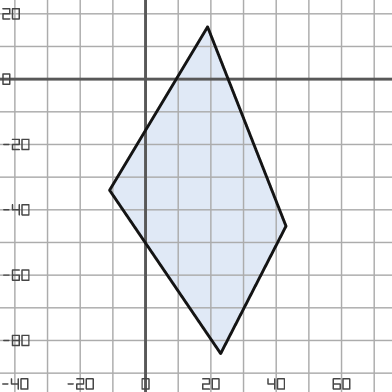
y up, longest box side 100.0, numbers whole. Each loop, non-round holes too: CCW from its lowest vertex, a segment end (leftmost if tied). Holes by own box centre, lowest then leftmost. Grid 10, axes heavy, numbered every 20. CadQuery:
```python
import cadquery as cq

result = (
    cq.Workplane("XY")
    .moveTo(23.0, -84.0)
    .lineTo(43.0, -45.0)
    .lineTo(19.0, 16.0)
    .lineTo(-11.0, -34.0)
    .close()
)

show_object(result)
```